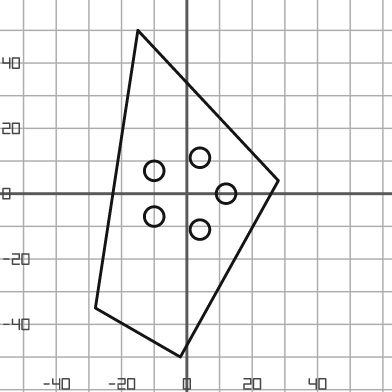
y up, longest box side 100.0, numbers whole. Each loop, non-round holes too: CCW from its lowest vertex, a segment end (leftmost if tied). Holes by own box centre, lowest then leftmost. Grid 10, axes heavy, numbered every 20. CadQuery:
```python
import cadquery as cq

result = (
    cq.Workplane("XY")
    .moveTo(-2.0, -50.0)
    .lineTo(28.0, 4.0)
    .lineTo(-15.0, 50.0)
    .lineTo(-28.0, -35.0)
    .close()
    .moveTo(4.0, -11.0)
    .circle(3.0)
    .moveTo(-10.0, -7.0)
    .circle(3.0)
    .moveTo(12.0, 0.0)
    .circle(3.0)
    .moveTo(-10.0, 7.0)
    .circle(3.0)
    .moveTo(4.0, 11.0)
    .circle(3.0)
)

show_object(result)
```